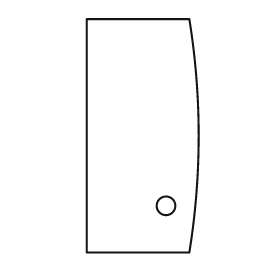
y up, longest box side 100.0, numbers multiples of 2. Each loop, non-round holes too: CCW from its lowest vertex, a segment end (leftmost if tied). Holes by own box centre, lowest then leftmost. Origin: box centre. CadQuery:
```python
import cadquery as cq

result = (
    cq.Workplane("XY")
    .moveTo(-24.0, -50.0)
    .lineTo(20.0, -50.0)
    .threePointArc((24.0, 0.0), (20.0, 50.0))
    .lineTo(-24.0, 50.0)
    .close()
    .moveTo(10.0, -30.0)
    .circle(4.0)
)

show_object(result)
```